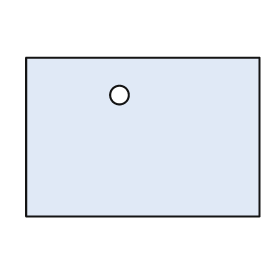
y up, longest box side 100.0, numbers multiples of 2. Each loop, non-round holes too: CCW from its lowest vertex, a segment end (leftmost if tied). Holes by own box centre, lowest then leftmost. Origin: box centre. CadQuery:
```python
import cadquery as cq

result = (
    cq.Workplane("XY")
    .moveTo(-50.0, -34.0)
    .lineTo(50.0, -34.0)
    .lineTo(50.0, 34.0)
    .lineTo(-50.0, 34.0)
    .close()
    .moveTo(-10.0, 18.0)
    .circle(4.0)
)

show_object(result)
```